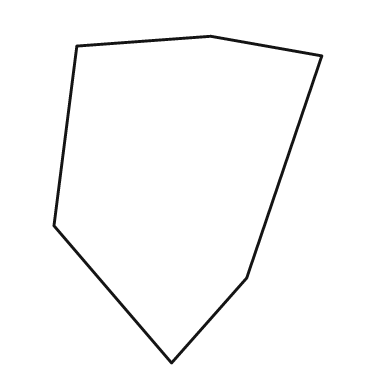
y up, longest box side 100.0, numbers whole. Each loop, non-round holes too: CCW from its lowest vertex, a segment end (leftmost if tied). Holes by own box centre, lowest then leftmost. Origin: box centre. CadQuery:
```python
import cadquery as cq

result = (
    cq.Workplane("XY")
    .moveTo(-5.0, -50.0)
    .lineTo(18.0, -24.0)
    .lineTo(41.0, 44.0)
    .lineTo(7.0, 50.0)
    .lineTo(-34.0, 47.0)
    .lineTo(-41.0, -8.0)
    .close()
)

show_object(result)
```